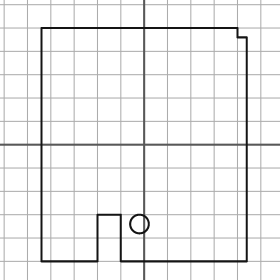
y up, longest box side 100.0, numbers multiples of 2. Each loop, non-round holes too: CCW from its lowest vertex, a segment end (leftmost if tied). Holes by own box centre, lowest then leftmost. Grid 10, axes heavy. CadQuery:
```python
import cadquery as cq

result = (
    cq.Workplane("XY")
    .moveTo(-44.0, -50.0)
    .lineTo(-20.0, -50.0)
    .lineTo(-20.0, -30.0)
    .lineTo(-10.0, -30.0)
    .lineTo(-10.0, -50.0)
    .lineTo(44.0, -50.0)
    .lineTo(44.0, 46.0)
    .lineTo(40.0, 46.0)
    .lineTo(40.0, 50.0)
    .lineTo(-44.0, 50.0)
    .close()
    .moveTo(-2.0, -34.0)
    .circle(4.0)
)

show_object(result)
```